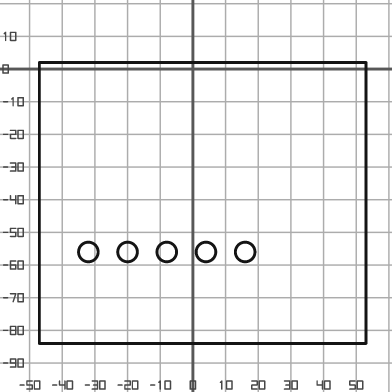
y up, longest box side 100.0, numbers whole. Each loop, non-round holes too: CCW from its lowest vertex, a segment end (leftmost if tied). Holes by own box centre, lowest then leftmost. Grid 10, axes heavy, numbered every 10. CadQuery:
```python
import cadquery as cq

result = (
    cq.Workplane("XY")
    .moveTo(-47.0, -84.0)
    .lineTo(53.0, -84.0)
    .lineTo(53.0, 2.0)
    .lineTo(-47.0, 2.0)
    .close()
    .moveTo(-32.0, -56.0)
    .circle(3.0)
    .moveTo(-20.0, -56.0)
    .circle(3.0)
    .moveTo(-8.0, -56.0)
    .circle(3.0)
    .moveTo(4.0, -56.0)
    .circle(3.0)
    .moveTo(16.0, -56.0)
    .circle(3.0)
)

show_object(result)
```